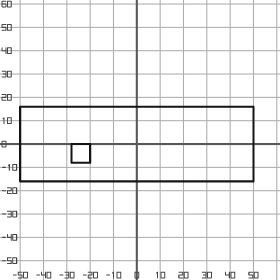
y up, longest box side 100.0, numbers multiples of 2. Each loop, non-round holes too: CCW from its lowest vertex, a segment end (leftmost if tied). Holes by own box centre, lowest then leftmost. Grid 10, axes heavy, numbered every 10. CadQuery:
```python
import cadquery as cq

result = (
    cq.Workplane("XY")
    .moveTo(-50.0, -16.0)
    .lineTo(50.0, -16.0)
    .lineTo(50.0, 16.0)
    .lineTo(-50.0, 16.0)
    .close()
    .moveTo(-28.0, -8.0)
    .lineTo(-20.0, -8.0)
    .lineTo(-20.0, 0.0)
    .lineTo(-28.0, 0.0)
    .close()
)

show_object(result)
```